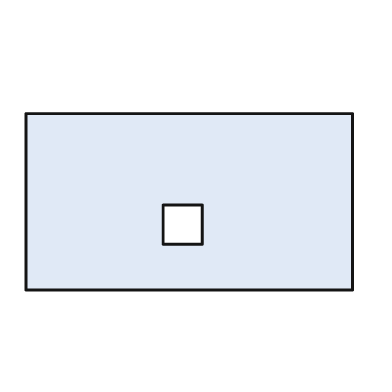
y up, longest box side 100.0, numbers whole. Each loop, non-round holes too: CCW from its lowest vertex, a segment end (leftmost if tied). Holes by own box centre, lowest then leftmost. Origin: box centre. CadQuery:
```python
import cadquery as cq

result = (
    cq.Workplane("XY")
    .moveTo(-50.0, -27.0)
    .lineTo(50.0, -27.0)
    .lineTo(50.0, 27.0)
    .lineTo(-50.0, 27.0)
    .close()
    .moveTo(-8.0, -13.0)
    .lineTo(4.0, -13.0)
    .lineTo(4.0, -1.0)
    .lineTo(-8.0, -1.0)
    .close()
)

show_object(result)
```